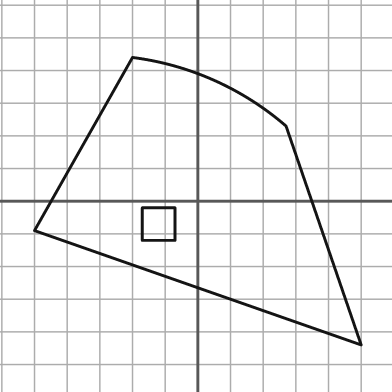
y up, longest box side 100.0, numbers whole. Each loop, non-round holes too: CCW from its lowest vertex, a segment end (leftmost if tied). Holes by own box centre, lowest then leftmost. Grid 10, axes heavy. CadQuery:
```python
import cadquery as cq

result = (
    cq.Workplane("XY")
    .moveTo(50.0, -44.0)
    .lineTo(27.0, 23.0)
    .threePointArc((5.0, 37.0), (-20.0, 44.0))
    .lineTo(-50.0, -9.0)
    .close()
    .moveTo(-17.0, -12.0)
    .lineTo(-7.0, -12.0)
    .lineTo(-7.0, -2.0)
    .lineTo(-17.0, -2.0)
    .close()
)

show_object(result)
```